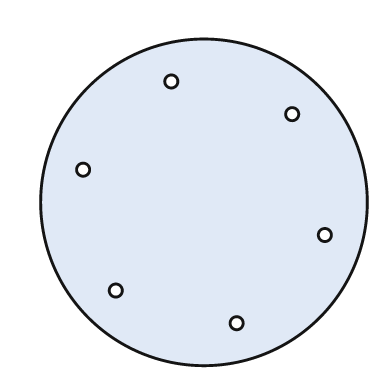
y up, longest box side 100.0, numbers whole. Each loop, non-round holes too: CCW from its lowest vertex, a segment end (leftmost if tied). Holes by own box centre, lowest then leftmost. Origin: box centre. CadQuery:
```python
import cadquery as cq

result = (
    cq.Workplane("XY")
    .moveTo(0.0, 0.0)
    .circle(50.0)
    .moveTo(10.0, -37.0)
    .circle(2.0)
    .moveTo(-27.0, -27.0)
    .circle(2.0)
    .moveTo(37.0, -10.0)
    .circle(2.0)
    .moveTo(-37.0, 10.0)
    .circle(2.0)
    .moveTo(27.0, 27.0)
    .circle(2.0)
    .moveTo(-10.0, 37.0)
    .circle(2.0)
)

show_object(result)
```